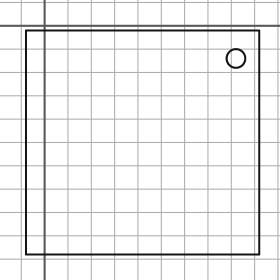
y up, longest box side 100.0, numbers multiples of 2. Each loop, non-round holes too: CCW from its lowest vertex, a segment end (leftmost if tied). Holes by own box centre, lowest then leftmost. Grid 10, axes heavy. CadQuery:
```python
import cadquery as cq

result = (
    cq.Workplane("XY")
    .moveTo(-8.0, -98.0)
    .lineTo(92.0, -98.0)
    .lineTo(92.0, -2.0)
    .lineTo(-8.0, -2.0)
    .close()
    .moveTo(82.0, -14.0)
    .circle(4.0)
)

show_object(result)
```